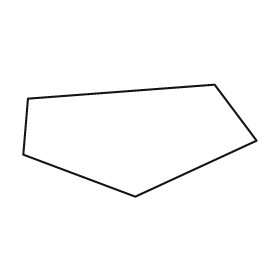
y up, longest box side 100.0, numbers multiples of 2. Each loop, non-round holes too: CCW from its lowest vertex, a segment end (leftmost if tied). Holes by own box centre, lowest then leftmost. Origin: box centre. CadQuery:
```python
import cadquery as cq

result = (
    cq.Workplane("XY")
    .moveTo(-2.0, -24.0)
    .lineTo(50.0, 0.0)
    .lineTo(32.0, 24.0)
    .lineTo(-48.0, 18.0)
    .lineTo(-50.0, -6.0)
    .close()
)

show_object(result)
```